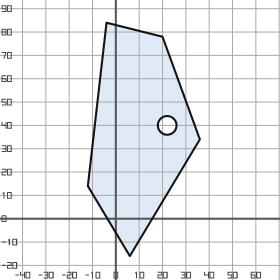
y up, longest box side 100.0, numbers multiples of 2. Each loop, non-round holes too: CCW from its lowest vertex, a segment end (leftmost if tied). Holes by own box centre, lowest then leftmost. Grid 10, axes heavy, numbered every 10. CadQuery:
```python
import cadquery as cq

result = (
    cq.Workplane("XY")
    .moveTo(6.0, -16.0)
    .lineTo(36.0, 34.0)
    .lineTo(20.0, 78.0)
    .lineTo(-4.0, 84.0)
    .lineTo(-12.0, 14.0)
    .close()
    .moveTo(22.0, 40.0)
    .circle(4.0)
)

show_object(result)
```